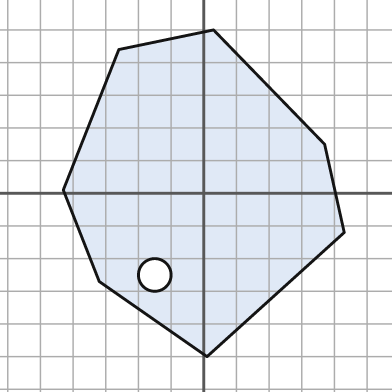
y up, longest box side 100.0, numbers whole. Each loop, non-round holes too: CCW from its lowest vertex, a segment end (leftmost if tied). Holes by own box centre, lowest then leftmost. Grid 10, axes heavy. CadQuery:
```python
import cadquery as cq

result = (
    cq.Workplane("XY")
    .moveTo(1.0, -50.0)
    .lineTo(43.0, -12.0)
    .lineTo(37.0, 15.0)
    .lineTo(3.0, 50.0)
    .lineTo(-26.0, 44.0)
    .lineTo(-43.0, 1.0)
    .lineTo(-32.0, -27.0)
    .close()
    .moveTo(-15.0, -25.0)
    .circle(5.0)
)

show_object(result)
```